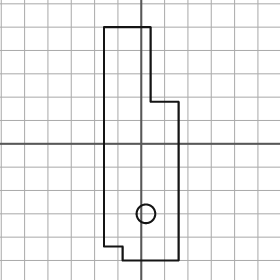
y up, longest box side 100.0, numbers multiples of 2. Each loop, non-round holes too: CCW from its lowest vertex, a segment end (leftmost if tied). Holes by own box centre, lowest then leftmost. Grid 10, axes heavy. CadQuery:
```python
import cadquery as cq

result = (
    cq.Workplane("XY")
    .moveTo(-8.0, -50.0)
    .lineTo(16.0, -50.0)
    .lineTo(16.0, 18.0)
    .lineTo(4.0, 18.0)
    .lineTo(4.0, 50.0)
    .lineTo(-16.0, 50.0)
    .lineTo(-16.0, -44.0)
    .lineTo(-8.0, -44.0)
    .close()
    .moveTo(2.0, -30.0)
    .circle(4.0)
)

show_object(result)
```